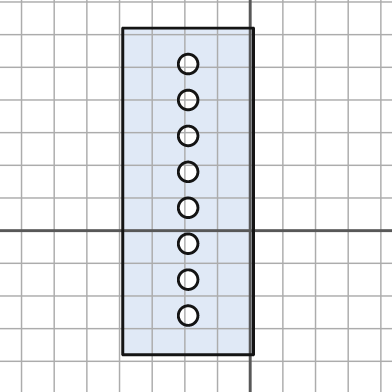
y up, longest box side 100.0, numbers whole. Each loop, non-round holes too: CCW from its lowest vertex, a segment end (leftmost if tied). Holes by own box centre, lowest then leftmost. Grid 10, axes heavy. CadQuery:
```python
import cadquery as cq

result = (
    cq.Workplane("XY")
    .moveTo(-39.0, -38.0)
    .lineTo(1.0, -38.0)
    .lineTo(1.0, 62.0)
    .lineTo(-39.0, 62.0)
    .close()
    .moveTo(-19.0, -26.0)
    .circle(3.0)
    .moveTo(-19.0, -15.0)
    .circle(3.0)
    .moveTo(-19.0, -4.0)
    .circle(3.0)
    .moveTo(-19.0, 7.0)
    .circle(3.0)
    .moveTo(-19.0, 18.0)
    .circle(3.0)
    .moveTo(-19.0, 29.0)
    .circle(3.0)
    .moveTo(-19.0, 40.0)
    .circle(3.0)
    .moveTo(-19.0, 51.0)
    .circle(3.0)
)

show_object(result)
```